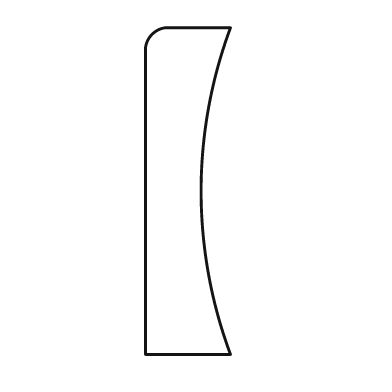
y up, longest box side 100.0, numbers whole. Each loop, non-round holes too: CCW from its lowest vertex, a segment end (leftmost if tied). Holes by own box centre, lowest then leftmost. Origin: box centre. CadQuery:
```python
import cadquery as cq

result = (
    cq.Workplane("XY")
    .moveTo(-13.0, -50.0)
    .lineTo(13.0, -50.0)
    .threePointArc((4.0, 0.0), (13.0, 50.0))
    .lineTo(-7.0, 50.0)
    .threePointArc((-11.0, 48.0), (-13.0, 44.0))
    .close()
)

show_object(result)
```